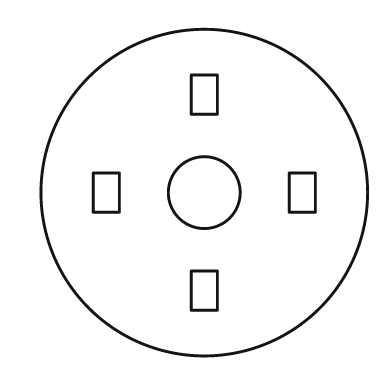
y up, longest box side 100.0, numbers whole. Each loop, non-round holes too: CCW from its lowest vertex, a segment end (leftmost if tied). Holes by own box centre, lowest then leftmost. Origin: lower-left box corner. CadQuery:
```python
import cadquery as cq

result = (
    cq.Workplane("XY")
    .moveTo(50.0, 50.0)
    .circle(50.0)
    .moveTo(46.0, 14.0)
    .lineTo(54.0, 14.0)
    .lineTo(54.0, 26.0)
    .lineTo(46.0, 26.0)
    .close()
    .moveTo(16.0, 44.0)
    .lineTo(24.0, 44.0)
    .lineTo(24.0, 56.0)
    .lineTo(16.0, 56.0)
    .close()
    .moveTo(50.0, 50.0)
    .circle(11.0)
    .moveTo(76.0, 44.0)
    .lineTo(84.0, 44.0)
    .lineTo(84.0, 56.0)
    .lineTo(76.0, 56.0)
    .close()
    .moveTo(46.0, 74.0)
    .lineTo(54.0, 74.0)
    .lineTo(54.0, 86.0)
    .lineTo(46.0, 86.0)
    .close()
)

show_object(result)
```